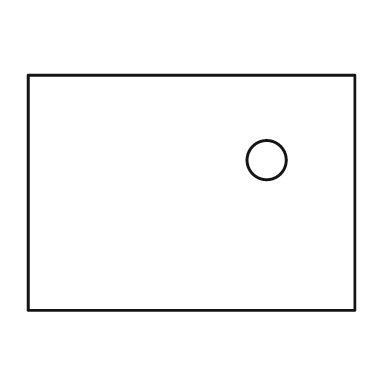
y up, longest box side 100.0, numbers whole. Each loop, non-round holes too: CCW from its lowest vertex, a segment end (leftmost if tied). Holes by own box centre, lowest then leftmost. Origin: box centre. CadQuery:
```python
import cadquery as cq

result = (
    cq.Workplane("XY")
    .moveTo(-50.0, -36.0)
    .lineTo(50.0, -36.0)
    .lineTo(50.0, 36.0)
    .lineTo(-50.0, 36.0)
    .close()
    .moveTo(23.0, 10.0)
    .circle(6.0)
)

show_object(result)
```